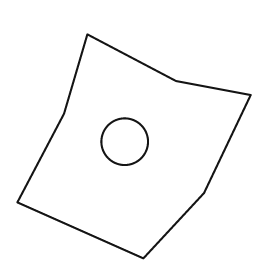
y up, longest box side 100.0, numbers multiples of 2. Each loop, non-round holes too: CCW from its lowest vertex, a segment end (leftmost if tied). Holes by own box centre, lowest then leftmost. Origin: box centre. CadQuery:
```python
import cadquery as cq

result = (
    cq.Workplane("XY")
    .moveTo(4.0, -48.0)
    .lineTo(30.0, -20.0)
    .lineTo(50.0, 22.0)
    .lineTo(18.0, 28.0)
    .lineTo(-20.0, 48.0)
    .lineTo(-30.0, 14.0)
    .lineTo(-50.0, -24.0)
    .close()
    .moveTo(-4.0, 2.0)
    .circle(10.0)
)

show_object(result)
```